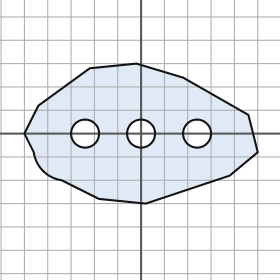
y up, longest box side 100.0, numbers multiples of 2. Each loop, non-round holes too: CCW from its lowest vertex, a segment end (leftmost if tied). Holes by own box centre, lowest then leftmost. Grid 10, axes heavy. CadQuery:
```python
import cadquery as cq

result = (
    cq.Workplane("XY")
    .moveTo(2.0, -30.0)
    .lineTo(38.0, -18.0)
    .lineTo(50.0, -8.0)
    .lineTo(46.0, 8.0)
    .lineTo(18.0, 24.0)
    .lineTo(-2.0, 30.0)
    .lineTo(-22.0, 28.0)
    .lineTo(-44.0, 12.0)
    .lineTo(-50.0, 0.0)
    .lineTo(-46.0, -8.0)
    .threePointArc((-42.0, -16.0), (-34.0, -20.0))
    .lineTo(-18.0, -28.0)
    .close()
    .moveTo(-24.0, 0.0)
    .circle(6.0)
    .moveTo(0.0, 0.0)
    .circle(6.0)
    .moveTo(24.0, 0.0)
    .circle(6.0)
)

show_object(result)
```